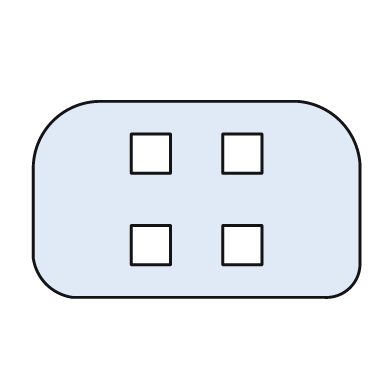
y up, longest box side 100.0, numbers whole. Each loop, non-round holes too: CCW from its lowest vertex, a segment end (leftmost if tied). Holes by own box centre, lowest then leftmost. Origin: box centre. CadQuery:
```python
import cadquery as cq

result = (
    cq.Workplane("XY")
    .moveTo(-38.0, -30.0)
    .lineTo(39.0, -30.0)
    .threePointArc((47.0, -27.0), (50.0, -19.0))
    .lineTo(50.0, 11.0)
    .threePointArc((44.0, 24.0), (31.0, 30.0))
    .lineTo(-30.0, 30.0)
    .threePointArc((-44.0, 24.0), (-50.0, 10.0))
    .lineTo(-50.0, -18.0)
    .threePointArc((-46.0, -26.0), (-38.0, -30.0))
    .close()
    .moveTo(-20.0, -20.0)
    .lineTo(-8.0, -20.0)
    .lineTo(-8.0, -8.0)
    .lineTo(-20.0, -8.0)
    .close()
    .moveTo(8.0, -20.0)
    .lineTo(20.0, -20.0)
    .lineTo(20.0, -8.0)
    .lineTo(8.0, -8.0)
    .close()
    .moveTo(-20.0, 8.0)
    .lineTo(-8.0, 8.0)
    .lineTo(-8.0, 20.0)
    .lineTo(-20.0, 20.0)
    .close()
    .moveTo(8.0, 8.0)
    .lineTo(20.0, 8.0)
    .lineTo(20.0, 20.0)
    .lineTo(8.0, 20.0)
    .close()
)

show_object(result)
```